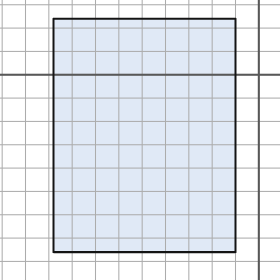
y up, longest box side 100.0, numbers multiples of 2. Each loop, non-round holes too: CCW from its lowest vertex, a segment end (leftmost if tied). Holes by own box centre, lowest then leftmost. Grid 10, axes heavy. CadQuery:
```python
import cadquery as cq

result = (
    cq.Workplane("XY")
    .moveTo(-88.0, -76.0)
    .lineTo(-10.0, -76.0)
    .lineTo(-10.0, 24.0)
    .lineTo(-88.0, 24.0)
    .close()
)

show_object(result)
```